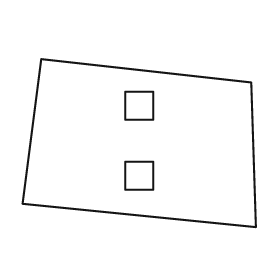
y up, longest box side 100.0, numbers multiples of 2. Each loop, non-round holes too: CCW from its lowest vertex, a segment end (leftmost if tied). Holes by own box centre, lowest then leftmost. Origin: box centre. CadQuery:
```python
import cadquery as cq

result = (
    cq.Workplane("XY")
    .moveTo(50.0, -36.0)
    .lineTo(48.0, 26.0)
    .lineTo(-42.0, 36.0)
    .lineTo(-50.0, -26.0)
    .close()
    .moveTo(-6.0, -20.0)
    .lineTo(6.0, -20.0)
    .lineTo(6.0, -8.0)
    .lineTo(-6.0, -8.0)
    .close()
    .moveTo(-6.0, 10.0)
    .lineTo(6.0, 10.0)
    .lineTo(6.0, 22.0)
    .lineTo(-6.0, 22.0)
    .close()
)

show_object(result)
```